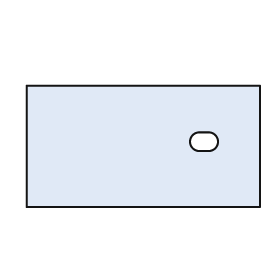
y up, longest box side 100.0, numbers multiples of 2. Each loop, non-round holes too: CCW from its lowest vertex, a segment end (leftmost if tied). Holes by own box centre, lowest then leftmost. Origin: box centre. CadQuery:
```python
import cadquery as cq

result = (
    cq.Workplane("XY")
    .moveTo(-50.0, -26.0)
    .lineTo(50.0, -26.0)
    .lineTo(50.0, 26.0)
    .lineTo(-50.0, 26.0)
    .close()
    .moveTo(24.0, -2.0)
    .lineTo(28.0, -2.0)
    .threePointArc((32.0, 2.0), (28.0, 6.0))
    .lineTo(24.0, 6.0)
    .threePointArc((20.0, 2.0), (24.0, -2.0))
    .close()
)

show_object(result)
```